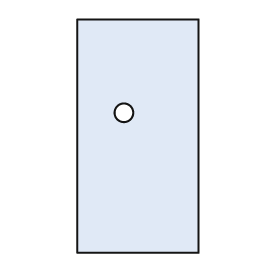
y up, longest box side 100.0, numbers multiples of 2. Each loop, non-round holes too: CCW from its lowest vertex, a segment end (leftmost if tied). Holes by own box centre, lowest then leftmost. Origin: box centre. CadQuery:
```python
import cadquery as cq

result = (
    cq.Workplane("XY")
    .moveTo(-26.0, -50.0)
    .lineTo(26.0, -50.0)
    .lineTo(26.0, 50.0)
    .lineTo(-26.0, 50.0)
    .close()
    .moveTo(-6.0, 10.0)
    .circle(4.0)
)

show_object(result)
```